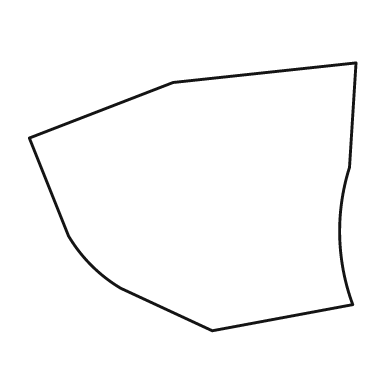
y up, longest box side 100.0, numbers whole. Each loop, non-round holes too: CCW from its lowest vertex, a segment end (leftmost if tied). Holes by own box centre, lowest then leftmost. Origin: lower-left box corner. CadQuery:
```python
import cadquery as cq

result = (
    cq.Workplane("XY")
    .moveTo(56.0, 0.0)
    .lineTo(99.0, 8.0)
    .threePointArc((95.0, 29.0), (98.0, 50.0))
    .lineTo(100.0, 82.0)
    .lineTo(44.0, 76.0)
    .lineTo(0.0, 59.0)
    .lineTo(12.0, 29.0)
    .threePointArc((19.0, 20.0), (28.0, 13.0))
    .close()
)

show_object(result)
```